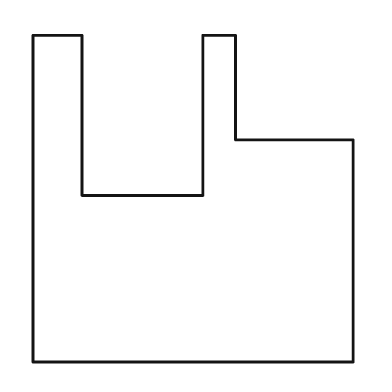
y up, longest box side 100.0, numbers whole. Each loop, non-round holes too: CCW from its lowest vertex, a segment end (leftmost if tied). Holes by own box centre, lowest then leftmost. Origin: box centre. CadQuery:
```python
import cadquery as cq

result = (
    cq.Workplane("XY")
    .moveTo(-49.0, -50.0)
    .lineTo(49.0, -50.0)
    .lineTo(49.0, 18.0)
    .lineTo(13.0, 18.0)
    .lineTo(13.0, 50.0)
    .lineTo(3.0, 50.0)
    .lineTo(3.0, 1.0)
    .lineTo(-34.0, 1.0)
    .lineTo(-34.0, 50.0)
    .lineTo(-49.0, 50.0)
    .close()
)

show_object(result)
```